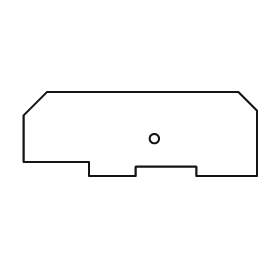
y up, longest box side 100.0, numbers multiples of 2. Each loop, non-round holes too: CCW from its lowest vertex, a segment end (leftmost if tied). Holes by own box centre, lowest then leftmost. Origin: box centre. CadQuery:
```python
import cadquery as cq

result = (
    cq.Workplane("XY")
    .moveTo(-22.0, -18.0)
    .lineTo(-2.0, -18.0)
    .lineTo(-2.0, -14.0)
    .lineTo(24.0, -14.0)
    .lineTo(24.0, -18.0)
    .lineTo(50.0, -18.0)
    .lineTo(50.0, 10.0)
    .lineTo(42.0, 18.0)
    .lineTo(-40.0, 18.0)
    .lineTo(-50.0, 8.0)
    .lineTo(-50.0, -12.0)
    .lineTo(-22.0, -12.0)
    .close()
    .moveTo(6.0, -2.0)
    .circle(2.0)
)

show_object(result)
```